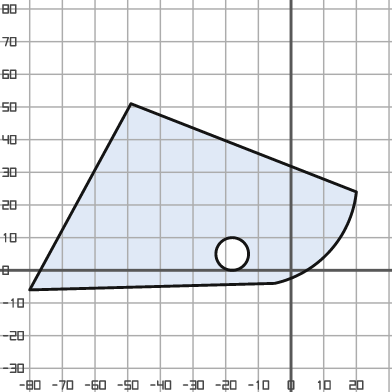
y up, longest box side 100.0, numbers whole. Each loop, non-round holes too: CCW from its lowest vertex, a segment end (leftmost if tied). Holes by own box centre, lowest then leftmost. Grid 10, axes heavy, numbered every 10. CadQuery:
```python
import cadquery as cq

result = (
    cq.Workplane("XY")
    .moveTo(-80.0, -6.0)
    .lineTo(-5.0, -4.0)
    .threePointArc((12.0, 6.0), (20.0, 24.0))
    .lineTo(-49.0, 51.0)
    .close()
    .moveTo(-18.0, 5.0)
    .circle(5.0)
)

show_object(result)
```